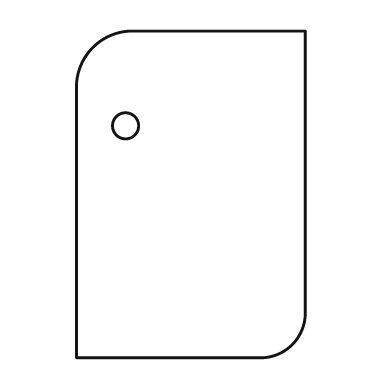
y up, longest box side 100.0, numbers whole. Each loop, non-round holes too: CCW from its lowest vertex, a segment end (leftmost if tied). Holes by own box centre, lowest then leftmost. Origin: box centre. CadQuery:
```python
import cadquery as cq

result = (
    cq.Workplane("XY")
    .moveTo(-35.0, -50.0)
    .lineTo(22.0, -50.0)
    .threePointArc((31.0, -46.0), (35.0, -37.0))
    .lineTo(35.0, 50.0)
    .lineTo(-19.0, 50.0)
    .threePointArc((-30.0, 45.0), (-35.0, 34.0))
    .close()
    .moveTo(-20.0, 21.0)
    .circle(4.0)
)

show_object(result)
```